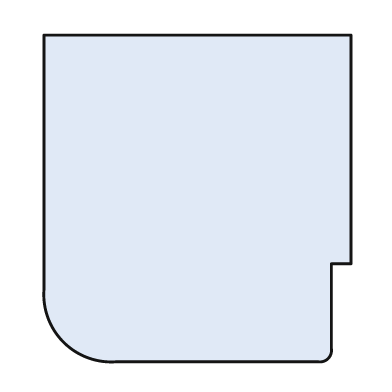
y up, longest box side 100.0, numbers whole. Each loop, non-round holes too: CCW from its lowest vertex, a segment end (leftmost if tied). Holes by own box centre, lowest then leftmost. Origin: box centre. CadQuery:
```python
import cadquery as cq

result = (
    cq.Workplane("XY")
    .moveTo(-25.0, -50.0)
    .lineTo(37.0, -50.0)
    .threePointArc((40.0, -49.0), (41.0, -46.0))
    .lineTo(41.0, -20.0)
    .lineTo(47.0, -20.0)
    .lineTo(47.0, 50.0)
    .lineTo(-47.0, 50.0)
    .lineTo(-47.0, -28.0)
    .threePointArc((-41.0, -44.0), (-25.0, -50.0))
    .close()
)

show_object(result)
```